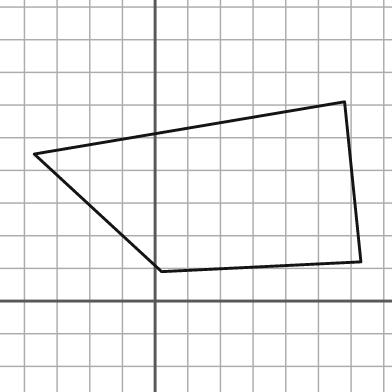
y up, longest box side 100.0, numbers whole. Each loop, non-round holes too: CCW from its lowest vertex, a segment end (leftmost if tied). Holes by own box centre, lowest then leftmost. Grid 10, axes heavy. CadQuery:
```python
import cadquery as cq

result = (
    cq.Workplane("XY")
    .moveTo(2.0, 9.0)
    .lineTo(63.0, 12.0)
    .lineTo(58.0, 61.0)
    .lineTo(-37.0, 45.0)
    .close()
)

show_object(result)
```